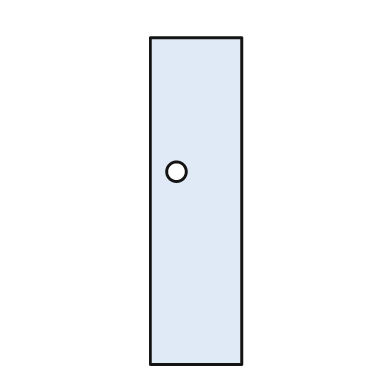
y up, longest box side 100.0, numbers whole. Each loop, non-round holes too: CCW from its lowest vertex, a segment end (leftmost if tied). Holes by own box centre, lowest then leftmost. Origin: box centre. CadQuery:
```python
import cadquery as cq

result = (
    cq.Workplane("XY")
    .moveTo(-14.0, -50.0)
    .lineTo(14.0, -50.0)
    .lineTo(14.0, 50.0)
    .lineTo(-14.0, 50.0)
    .close()
    .moveTo(-6.0, 9.0)
    .circle(3.0)
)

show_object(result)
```